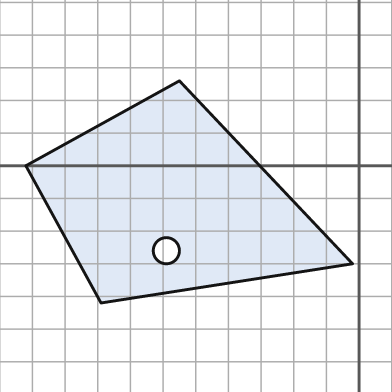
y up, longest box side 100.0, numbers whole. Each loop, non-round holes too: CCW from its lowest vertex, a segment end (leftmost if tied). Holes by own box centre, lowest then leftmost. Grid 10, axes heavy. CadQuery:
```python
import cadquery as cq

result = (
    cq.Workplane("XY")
    .moveTo(-79.0, -42.0)
    .lineTo(-2.0, -30.0)
    .lineTo(-55.0, 26.0)
    .lineTo(-102.0, 0.0)
    .close()
    .moveTo(-59.0, -26.0)
    .circle(4.0)
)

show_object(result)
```